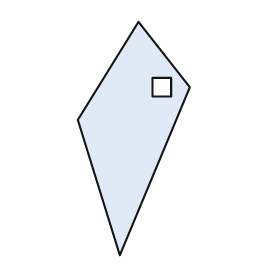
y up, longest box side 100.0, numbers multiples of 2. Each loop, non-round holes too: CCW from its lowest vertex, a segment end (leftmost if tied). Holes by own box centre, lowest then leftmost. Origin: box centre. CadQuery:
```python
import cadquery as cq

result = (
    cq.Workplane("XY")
    .moveTo(-6.0, -50.0)
    .lineTo(24.0, 22.0)
    .lineTo(2.0, 50.0)
    .lineTo(-24.0, 8.0)
    .close()
    .moveTo(8.0, 18.0)
    .lineTo(16.0, 18.0)
    .lineTo(16.0, 26.0)
    .lineTo(8.0, 26.0)
    .close()
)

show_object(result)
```